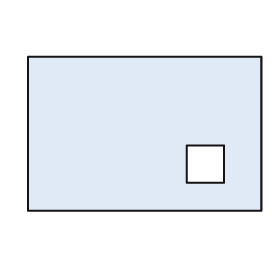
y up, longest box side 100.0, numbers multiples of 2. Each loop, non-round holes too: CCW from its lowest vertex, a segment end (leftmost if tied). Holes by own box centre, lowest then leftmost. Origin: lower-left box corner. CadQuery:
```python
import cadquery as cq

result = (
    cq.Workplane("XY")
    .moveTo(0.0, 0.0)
    .lineTo(100.0, 0.0)
    .lineTo(100.0, 66.0)
    .lineTo(0.0, 66.0)
    .close()
    .moveTo(68.0, 12.0)
    .lineTo(84.0, 12.0)
    .lineTo(84.0, 28.0)
    .lineTo(68.0, 28.0)
    .close()
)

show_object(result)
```